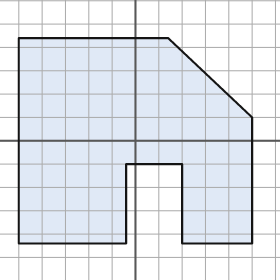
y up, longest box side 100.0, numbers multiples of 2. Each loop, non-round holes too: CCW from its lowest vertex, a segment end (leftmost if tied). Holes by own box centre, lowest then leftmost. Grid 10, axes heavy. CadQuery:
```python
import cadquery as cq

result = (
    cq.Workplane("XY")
    .moveTo(-50.0, -44.0)
    .lineTo(-4.0, -44.0)
    .lineTo(-4.0, -10.0)
    .lineTo(20.0, -10.0)
    .lineTo(20.0, -44.0)
    .lineTo(50.0, -44.0)
    .lineTo(50.0, 10.0)
    .lineTo(14.0, 44.0)
    .lineTo(-50.0, 44.0)
    .close()
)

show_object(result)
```